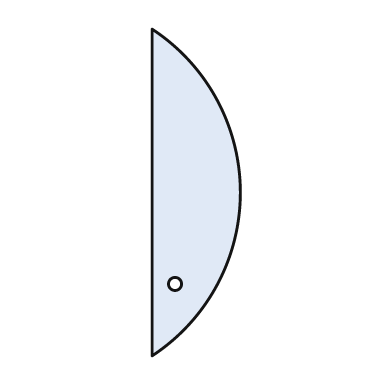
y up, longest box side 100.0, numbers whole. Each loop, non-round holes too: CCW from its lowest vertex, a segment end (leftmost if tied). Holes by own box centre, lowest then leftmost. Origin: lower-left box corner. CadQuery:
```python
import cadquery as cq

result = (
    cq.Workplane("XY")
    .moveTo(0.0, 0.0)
    .threePointArc((27.0, 50.0), (0.0, 100.0))
    .close()
    .moveTo(7.0, 22.0)
    .circle(2.0)
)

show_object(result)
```